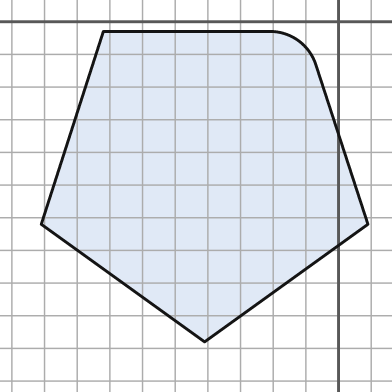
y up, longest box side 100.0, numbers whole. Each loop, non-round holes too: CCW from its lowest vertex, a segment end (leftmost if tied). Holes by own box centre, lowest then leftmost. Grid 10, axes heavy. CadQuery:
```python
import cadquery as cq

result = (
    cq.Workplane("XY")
    .moveTo(-41.0, -98.0)
    .lineTo(9.0, -62.0)
    .lineTo(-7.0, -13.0)
    .threePointArc((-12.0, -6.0), (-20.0, -3.0))
    .lineTo(-72.0, -3.0)
    .lineTo(-91.0, -62.0)
    .close()
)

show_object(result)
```